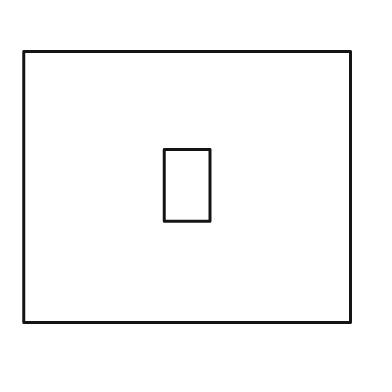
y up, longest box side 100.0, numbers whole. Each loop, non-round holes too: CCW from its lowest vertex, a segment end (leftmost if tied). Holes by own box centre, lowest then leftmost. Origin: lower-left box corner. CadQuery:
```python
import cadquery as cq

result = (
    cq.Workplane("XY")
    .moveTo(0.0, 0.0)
    .lineTo(100.0, 0.0)
    .lineTo(100.0, 83.0)
    .lineTo(0.0, 83.0)
    .close()
    .moveTo(43.0, 31.0)
    .lineTo(57.0, 31.0)
    .lineTo(57.0, 53.0)
    .lineTo(43.0, 53.0)
    .close()
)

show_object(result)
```